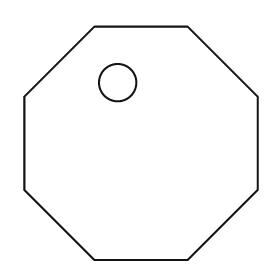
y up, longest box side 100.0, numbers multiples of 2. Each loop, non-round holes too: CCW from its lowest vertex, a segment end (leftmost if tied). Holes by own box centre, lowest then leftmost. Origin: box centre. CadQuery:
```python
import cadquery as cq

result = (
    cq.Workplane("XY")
    .moveTo(-20.0, -50.0)
    .lineTo(20.0, -50.0)
    .lineTo(50.0, -20.0)
    .lineTo(50.0, 20.0)
    .lineTo(20.0, 50.0)
    .lineTo(-20.0, 50.0)
    .lineTo(-50.0, 20.0)
    .lineTo(-50.0, -20.0)
    .close()
    .moveTo(-10.0, 26.0)
    .circle(8.0)
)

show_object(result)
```